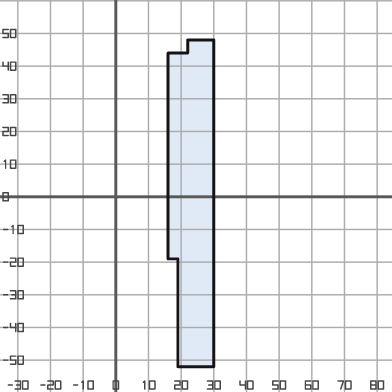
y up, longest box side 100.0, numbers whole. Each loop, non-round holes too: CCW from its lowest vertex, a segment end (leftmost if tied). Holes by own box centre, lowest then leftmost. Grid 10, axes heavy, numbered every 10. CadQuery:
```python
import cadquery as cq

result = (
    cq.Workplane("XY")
    .moveTo(19.0, -52.0)
    .lineTo(30.0, -52.0)
    .lineTo(30.0, 48.0)
    .lineTo(22.0, 48.0)
    .lineTo(22.0, 44.0)
    .lineTo(16.0, 44.0)
    .lineTo(16.0, -19.0)
    .lineTo(19.0, -19.0)
    .close()
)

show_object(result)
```